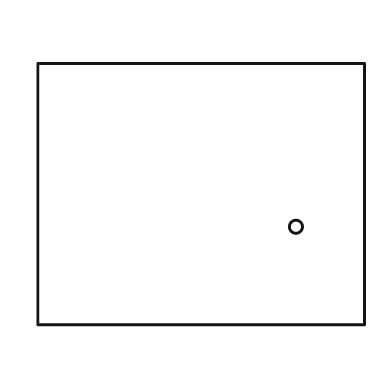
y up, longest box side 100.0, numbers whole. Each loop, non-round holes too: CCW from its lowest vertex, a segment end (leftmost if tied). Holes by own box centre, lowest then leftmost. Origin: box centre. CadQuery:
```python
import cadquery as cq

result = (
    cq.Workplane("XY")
    .moveTo(-50.0, -40.0)
    .lineTo(50.0, -40.0)
    .lineTo(50.0, 40.0)
    .lineTo(-50.0, 40.0)
    .close()
    .moveTo(29.0, -10.0)
    .circle(2.0)
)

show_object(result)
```